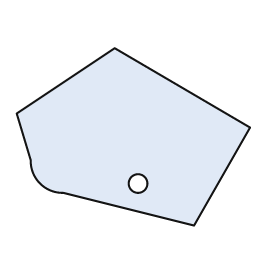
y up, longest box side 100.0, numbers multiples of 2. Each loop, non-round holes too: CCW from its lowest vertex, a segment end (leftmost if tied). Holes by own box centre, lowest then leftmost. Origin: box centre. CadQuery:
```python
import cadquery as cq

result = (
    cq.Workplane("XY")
    .moveTo(26.0, -38.0)
    .lineTo(50.0, 4.0)
    .lineTo(-8.0, 38.0)
    .lineTo(-50.0, 10.0)
    .lineTo(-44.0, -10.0)
    .threePointArc((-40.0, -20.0), (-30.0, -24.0))
    .close()
    .moveTo(2.0, -20.0)
    .circle(4.0)
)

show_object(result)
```